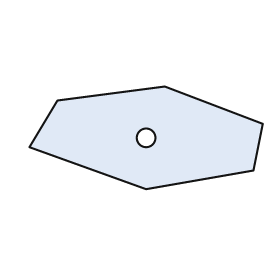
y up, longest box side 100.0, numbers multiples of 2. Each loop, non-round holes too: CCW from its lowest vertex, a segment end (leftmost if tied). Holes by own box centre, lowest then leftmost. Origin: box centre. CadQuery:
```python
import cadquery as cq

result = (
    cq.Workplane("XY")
    .moveTo(0.0, -22.0)
    .lineTo(46.0, -14.0)
    .lineTo(50.0, 6.0)
    .lineTo(8.0, 22.0)
    .lineTo(-38.0, 16.0)
    .lineTo(-50.0, -4.0)
    .close()
    .moveTo(0.0, 0.0)
    .circle(4.0)
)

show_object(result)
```